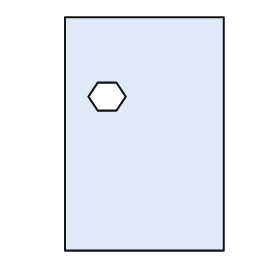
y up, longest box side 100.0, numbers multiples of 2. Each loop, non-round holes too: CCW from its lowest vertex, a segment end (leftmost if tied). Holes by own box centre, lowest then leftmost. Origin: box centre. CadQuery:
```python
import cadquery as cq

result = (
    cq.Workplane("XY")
    .moveTo(-34.0, -50.0)
    .lineTo(34.0, -50.0)
    .lineTo(34.0, 50.0)
    .lineTo(-34.0, 50.0)
    .close()
    .moveTo(-20.0, 10.0)
    .lineTo(-12.0, 10.0)
    .lineTo(-8.0, 16.0)
    .lineTo(-12.0, 22.0)
    .lineTo(-20.0, 22.0)
    .lineTo(-24.0, 16.0)
    .close()
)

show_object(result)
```